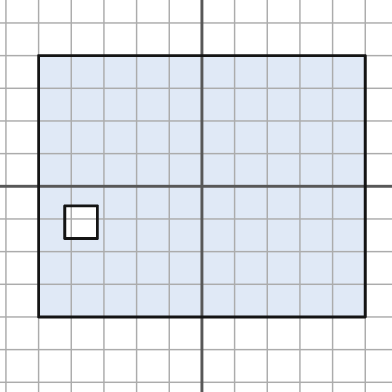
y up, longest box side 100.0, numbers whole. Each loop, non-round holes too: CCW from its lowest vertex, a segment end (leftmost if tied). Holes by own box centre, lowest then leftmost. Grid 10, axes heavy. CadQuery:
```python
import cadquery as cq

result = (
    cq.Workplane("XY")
    .moveTo(-50.0, -40.0)
    .lineTo(50.0, -40.0)
    .lineTo(50.0, 40.0)
    .lineTo(-50.0, 40.0)
    .close()
    .moveTo(-42.0, -16.0)
    .lineTo(-32.0, -16.0)
    .lineTo(-32.0, -6.0)
    .lineTo(-42.0, -6.0)
    .close()
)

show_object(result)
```